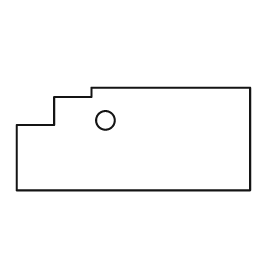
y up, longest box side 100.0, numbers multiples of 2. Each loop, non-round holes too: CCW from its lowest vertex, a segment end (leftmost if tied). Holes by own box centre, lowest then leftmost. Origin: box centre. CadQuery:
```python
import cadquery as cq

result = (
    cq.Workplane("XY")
    .moveTo(-50.0, -22.0)
    .lineTo(50.0, -22.0)
    .lineTo(50.0, 22.0)
    .lineTo(-18.0, 22.0)
    .lineTo(-18.0, 18.0)
    .lineTo(-34.0, 18.0)
    .lineTo(-34.0, 6.0)
    .lineTo(-50.0, 6.0)
    .close()
    .moveTo(-12.0, 8.0)
    .circle(4.0)
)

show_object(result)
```